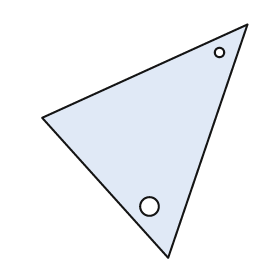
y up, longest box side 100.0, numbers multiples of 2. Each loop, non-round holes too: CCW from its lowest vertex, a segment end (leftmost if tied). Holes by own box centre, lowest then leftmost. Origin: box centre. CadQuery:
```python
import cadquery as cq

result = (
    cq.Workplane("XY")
    .moveTo(10.0, -50.0)
    .lineTo(44.0, 50.0)
    .lineTo(-44.0, 10.0)
    .close()
    .moveTo(2.0, -28.0)
    .circle(4.0)
    .moveTo(32.0, 38.0)
    .circle(2.0)
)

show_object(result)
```